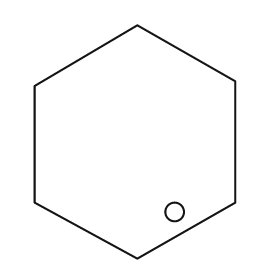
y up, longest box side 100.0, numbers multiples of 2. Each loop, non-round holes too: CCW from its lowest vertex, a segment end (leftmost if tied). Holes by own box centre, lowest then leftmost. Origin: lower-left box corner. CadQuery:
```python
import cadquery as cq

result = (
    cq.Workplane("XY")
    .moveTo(44.0, 0.0)
    .lineTo(86.0, 24.0)
    .lineTo(86.0, 76.0)
    .lineTo(44.0, 100.0)
    .lineTo(0.0, 74.0)
    .lineTo(0.0, 24.0)
    .close()
    .moveTo(60.0, 20.0)
    .circle(4.0)
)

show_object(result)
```